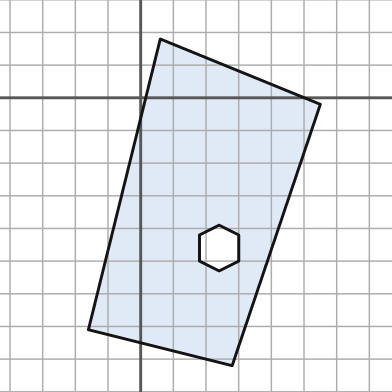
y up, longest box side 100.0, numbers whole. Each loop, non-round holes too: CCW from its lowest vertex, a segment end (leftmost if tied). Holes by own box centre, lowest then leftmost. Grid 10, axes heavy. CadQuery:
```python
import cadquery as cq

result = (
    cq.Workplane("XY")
    .moveTo(28.0, -82.0)
    .lineTo(55.0, -2.0)
    .lineTo(6.0, 18.0)
    .lineTo(-16.0, -71.0)
    .close()
    .moveTo(24.0, -53.0)
    .lineTo(30.0, -50.0)
    .lineTo(30.0, -42.0)
    .lineTo(24.0, -39.0)
    .lineTo(18.0, -42.0)
    .lineTo(18.0, -50.0)
    .close()
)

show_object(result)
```